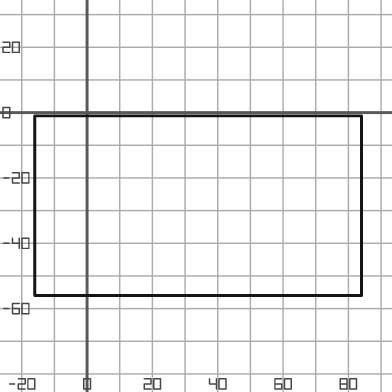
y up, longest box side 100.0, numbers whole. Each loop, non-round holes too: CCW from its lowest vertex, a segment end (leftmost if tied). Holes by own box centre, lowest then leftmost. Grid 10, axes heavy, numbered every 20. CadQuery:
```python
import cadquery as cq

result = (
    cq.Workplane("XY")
    .moveTo(-16.0, -56.0)
    .lineTo(84.0, -56.0)
    .lineTo(84.0, -1.0)
    .lineTo(-16.0, -1.0)
    .close()
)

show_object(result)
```